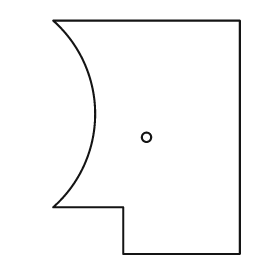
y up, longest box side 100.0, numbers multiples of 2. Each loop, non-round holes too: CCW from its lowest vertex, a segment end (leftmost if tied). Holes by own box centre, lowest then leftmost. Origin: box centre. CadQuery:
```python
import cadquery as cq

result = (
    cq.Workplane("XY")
    .moveTo(-10.0, -50.0)
    .lineTo(40.0, -50.0)
    .lineTo(40.0, 50.0)
    .lineTo(-40.0, 50.0)
    .threePointArc((-22.0, 10.0), (-40.0, -30.0))
    .lineTo(-10.0, -30.0)
    .close()
    .moveTo(0.0, 0.0)
    .circle(2.0)
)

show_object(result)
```